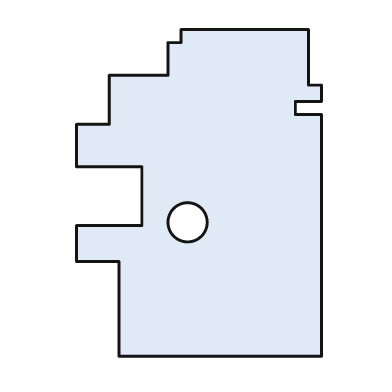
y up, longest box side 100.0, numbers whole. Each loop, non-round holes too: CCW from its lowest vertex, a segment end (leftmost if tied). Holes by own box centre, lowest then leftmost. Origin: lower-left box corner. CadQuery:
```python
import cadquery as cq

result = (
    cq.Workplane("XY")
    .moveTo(13.0, 0.0)
    .lineTo(75.0, 0.0)
    .lineTo(75.0, 74.0)
    .lineTo(67.0, 74.0)
    .lineTo(67.0, 78.0)
    .lineTo(75.0, 78.0)
    .lineTo(75.0, 83.0)
    .lineTo(71.0, 83.0)
    .lineTo(71.0, 100.0)
    .lineTo(32.0, 100.0)
    .lineTo(32.0, 96.0)
    .lineTo(28.0, 96.0)
    .lineTo(28.0, 86.0)
    .lineTo(10.0, 86.0)
    .lineTo(10.0, 71.0)
    .lineTo(0.0, 71.0)
    .lineTo(0.0, 58.0)
    .lineTo(20.0, 58.0)
    .lineTo(20.0, 40.0)
    .lineTo(0.0, 40.0)
    .lineTo(0.0, 29.0)
    .lineTo(13.0, 29.0)
    .close()
    .moveTo(34.0, 41.0)
    .circle(6.0)
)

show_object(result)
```